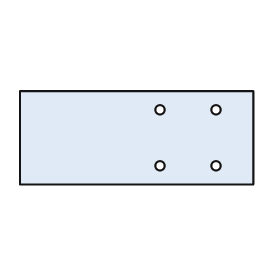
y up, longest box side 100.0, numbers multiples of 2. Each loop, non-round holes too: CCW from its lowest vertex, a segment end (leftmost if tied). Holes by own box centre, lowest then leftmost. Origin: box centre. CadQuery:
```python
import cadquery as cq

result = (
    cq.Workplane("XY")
    .moveTo(-50.0, -20.0)
    .lineTo(50.0, -20.0)
    .lineTo(50.0, 20.0)
    .lineTo(-50.0, 20.0)
    .close()
    .moveTo(10.0, -12.0)
    .circle(2.0)
    .moveTo(34.0, -12.0)
    .circle(2.0)
    .moveTo(10.0, 12.0)
    .circle(2.0)
    .moveTo(34.0, 12.0)
    .circle(2.0)
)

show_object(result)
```